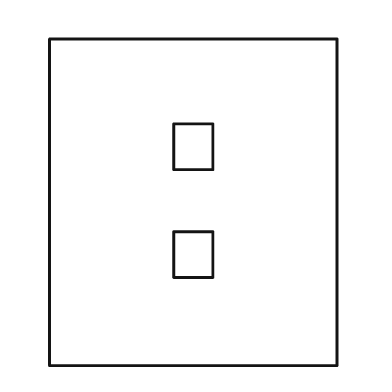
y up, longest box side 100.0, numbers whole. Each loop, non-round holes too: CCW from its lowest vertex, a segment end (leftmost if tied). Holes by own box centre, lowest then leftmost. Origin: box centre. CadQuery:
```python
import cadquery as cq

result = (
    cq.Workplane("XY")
    .moveTo(-44.0, -50.0)
    .lineTo(44.0, -50.0)
    .lineTo(44.0, 50.0)
    .lineTo(-44.0, 50.0)
    .close()
    .moveTo(-6.0, -23.0)
    .lineTo(6.0, -23.0)
    .lineTo(6.0, -9.0)
    .lineTo(-6.0, -9.0)
    .close()
    .moveTo(-6.0, 10.0)
    .lineTo(6.0, 10.0)
    .lineTo(6.0, 24.0)
    .lineTo(-6.0, 24.0)
    .close()
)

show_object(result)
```